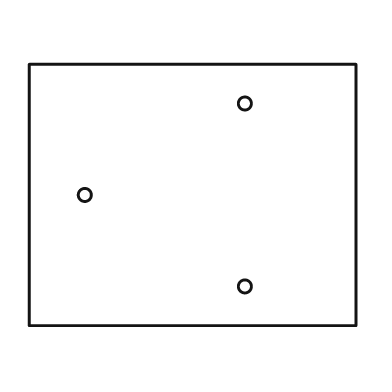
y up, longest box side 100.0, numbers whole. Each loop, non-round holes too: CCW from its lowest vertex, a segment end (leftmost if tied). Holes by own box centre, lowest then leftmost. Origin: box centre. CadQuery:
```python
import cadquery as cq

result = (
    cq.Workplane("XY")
    .moveTo(-50.0, -40.0)
    .lineTo(50.0, -40.0)
    .lineTo(50.0, 40.0)
    .lineTo(-50.0, 40.0)
    .close()
    .moveTo(16.0, -28.0)
    .circle(2.0)
    .moveTo(-33.0, 0.0)
    .circle(2.0)
    .moveTo(16.0, 28.0)
    .circle(2.0)
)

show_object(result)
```